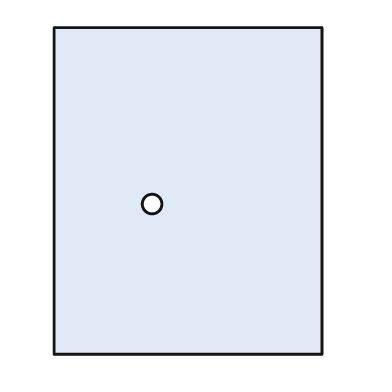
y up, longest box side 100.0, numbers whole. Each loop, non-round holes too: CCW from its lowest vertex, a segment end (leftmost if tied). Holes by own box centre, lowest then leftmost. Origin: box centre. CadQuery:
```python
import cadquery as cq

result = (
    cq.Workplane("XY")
    .moveTo(-41.0, -50.0)
    .lineTo(41.0, -50.0)
    .lineTo(41.0, 50.0)
    .lineTo(-41.0, 50.0)
    .close()
    .moveTo(-11.0, -4.0)
    .circle(3.0)
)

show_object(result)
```